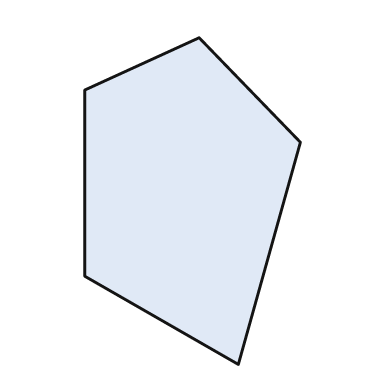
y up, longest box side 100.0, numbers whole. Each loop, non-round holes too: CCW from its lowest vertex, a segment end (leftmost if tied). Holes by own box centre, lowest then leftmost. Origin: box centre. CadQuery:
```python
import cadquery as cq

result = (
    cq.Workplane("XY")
    .moveTo(14.0, -50.0)
    .lineTo(33.0, 18.0)
    .lineTo(2.0, 50.0)
    .lineTo(-33.0, 34.0)
    .lineTo(-33.0, -23.0)
    .close()
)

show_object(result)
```